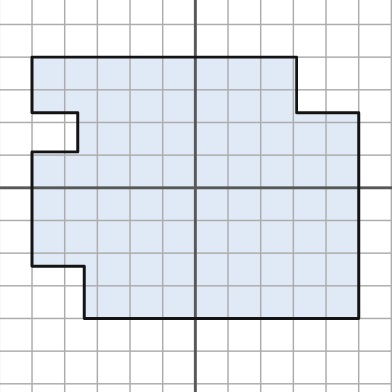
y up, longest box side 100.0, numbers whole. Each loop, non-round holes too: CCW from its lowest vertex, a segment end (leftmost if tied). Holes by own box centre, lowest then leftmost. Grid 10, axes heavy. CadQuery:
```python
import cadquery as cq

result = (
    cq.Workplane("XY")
    .moveTo(-34.0, -40.0)
    .lineTo(50.0, -40.0)
    .lineTo(50.0, 23.0)
    .lineTo(31.0, 23.0)
    .lineTo(31.0, 40.0)
    .lineTo(-50.0, 40.0)
    .lineTo(-50.0, 23.0)
    .lineTo(-36.0, 23.0)
    .lineTo(-36.0, 11.0)
    .lineTo(-50.0, 11.0)
    .lineTo(-50.0, -24.0)
    .lineTo(-34.0, -24.0)
    .close()
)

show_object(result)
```